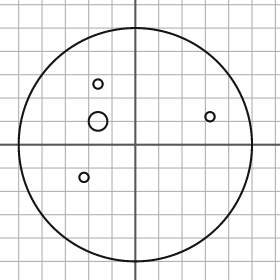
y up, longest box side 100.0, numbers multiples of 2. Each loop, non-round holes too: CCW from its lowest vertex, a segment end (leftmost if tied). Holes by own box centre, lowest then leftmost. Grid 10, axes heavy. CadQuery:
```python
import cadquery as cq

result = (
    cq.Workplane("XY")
    .moveTo(0.0, 0.0)
    .circle(50.0)
    .moveTo(-22.0, -14.0)
    .circle(2.0)
    .moveTo(-16.0, 10.0)
    .circle(4.0)
    .moveTo(32.0, 12.0)
    .circle(2.0)
    .moveTo(-16.0, 26.0)
    .circle(2.0)
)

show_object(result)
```